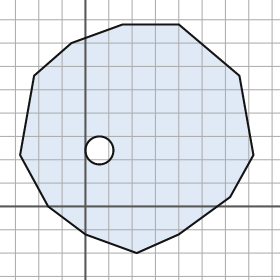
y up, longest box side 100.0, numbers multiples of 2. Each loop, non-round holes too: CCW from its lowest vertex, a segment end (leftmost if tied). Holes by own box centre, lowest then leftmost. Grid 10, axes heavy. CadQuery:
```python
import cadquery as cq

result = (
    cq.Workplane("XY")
    .moveTo(22.0, -20.0)
    .lineTo(40.0, -12.0)
    .lineTo(62.0, 4.0)
    .lineTo(72.0, 22.0)
    .lineTo(66.0, 56.0)
    .lineTo(40.0, 78.0)
    .lineTo(16.0, 78.0)
    .lineTo(-6.0, 70.0)
    .lineTo(-22.0, 56.0)
    .lineTo(-28.0, 22.0)
    .lineTo(-16.0, 0.0)
    .lineTo(0.0, -12.0)
    .close()
    .moveTo(6.0, 24.0)
    .circle(6.0)
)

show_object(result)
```